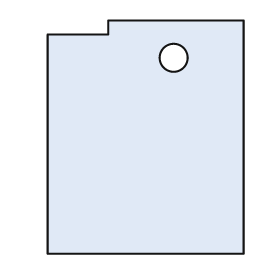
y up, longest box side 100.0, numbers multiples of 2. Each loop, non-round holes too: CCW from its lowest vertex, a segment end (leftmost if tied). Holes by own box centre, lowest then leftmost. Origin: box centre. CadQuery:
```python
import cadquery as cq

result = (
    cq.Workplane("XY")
    .moveTo(-42.0, -50.0)
    .lineTo(42.0, -50.0)
    .lineTo(42.0, 50.0)
    .lineTo(-16.0, 50.0)
    .lineTo(-16.0, 44.0)
    .lineTo(-42.0, 44.0)
    .close()
    .moveTo(12.0, 34.0)
    .circle(6.0)
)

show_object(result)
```